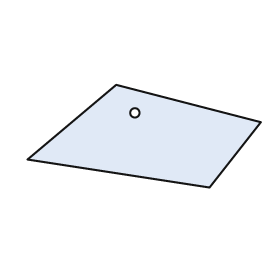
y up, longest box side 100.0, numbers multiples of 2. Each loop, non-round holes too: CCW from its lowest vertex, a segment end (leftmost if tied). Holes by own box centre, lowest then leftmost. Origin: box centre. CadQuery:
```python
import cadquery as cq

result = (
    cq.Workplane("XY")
    .moveTo(28.0, -22.0)
    .lineTo(50.0, 6.0)
    .lineTo(-12.0, 22.0)
    .lineTo(-50.0, -10.0)
    .close()
    .moveTo(-4.0, 10.0)
    .circle(2.0)
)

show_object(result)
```